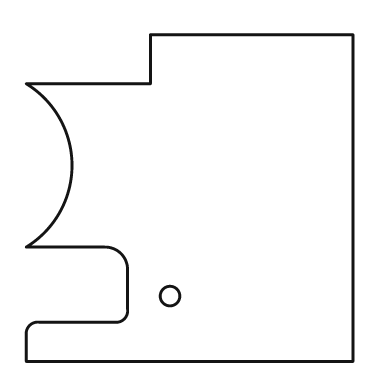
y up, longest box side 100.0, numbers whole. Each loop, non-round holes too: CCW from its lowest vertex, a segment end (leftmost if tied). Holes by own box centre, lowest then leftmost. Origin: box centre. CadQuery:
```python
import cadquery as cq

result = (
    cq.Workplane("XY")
    .moveTo(-50.0, -50.0)
    .lineTo(50.0, -50.0)
    .lineTo(50.0, 50.0)
    .lineTo(-12.0, 50.0)
    .lineTo(-12.0, 35.0)
    .lineTo(-50.0, 35.0)
    .threePointArc((-36.0, 10.0), (-50.0, -15.0))
    .lineTo(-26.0, -15.0)
    .threePointArc((-21.0, -17.0), (-19.0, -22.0))
    .lineTo(-19.0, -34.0)
    .threePointArc((-20.0, -37.0), (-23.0, -38.0))
    .lineTo(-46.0, -38.0)
    .threePointArc((-49.0, -39.0), (-50.0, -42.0))
    .close()
    .moveTo(-6.0, -30.0)
    .circle(3.0)
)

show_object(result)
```